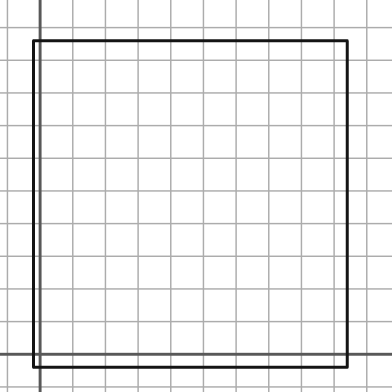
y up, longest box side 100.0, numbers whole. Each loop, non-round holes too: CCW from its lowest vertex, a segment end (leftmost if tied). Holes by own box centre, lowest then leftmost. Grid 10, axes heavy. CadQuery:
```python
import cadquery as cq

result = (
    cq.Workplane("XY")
    .moveTo(-2.0, -4.0)
    .lineTo(94.0, -4.0)
    .lineTo(94.0, 96.0)
    .lineTo(-2.0, 96.0)
    .close()
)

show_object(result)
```